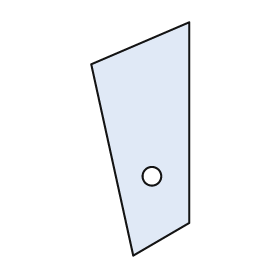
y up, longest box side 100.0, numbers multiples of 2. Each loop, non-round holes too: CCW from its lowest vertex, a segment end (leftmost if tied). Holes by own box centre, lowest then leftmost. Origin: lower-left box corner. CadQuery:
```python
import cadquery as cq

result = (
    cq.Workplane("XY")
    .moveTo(18.0, 0.0)
    .lineTo(42.0, 14.0)
    .lineTo(42.0, 100.0)
    .lineTo(0.0, 82.0)
    .close()
    .moveTo(26.0, 34.0)
    .circle(4.0)
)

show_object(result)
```